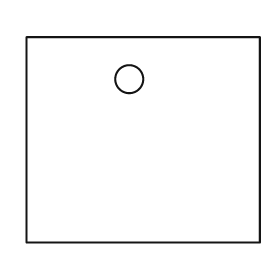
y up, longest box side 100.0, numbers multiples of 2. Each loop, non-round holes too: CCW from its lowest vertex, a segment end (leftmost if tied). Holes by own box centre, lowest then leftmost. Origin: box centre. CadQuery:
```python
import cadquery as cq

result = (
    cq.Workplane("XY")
    .moveTo(-50.0, -44.0)
    .lineTo(50.0, -44.0)
    .lineTo(50.0, 44.0)
    .lineTo(-50.0, 44.0)
    .close()
    .moveTo(-6.0, 26.0)
    .circle(6.0)
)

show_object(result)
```